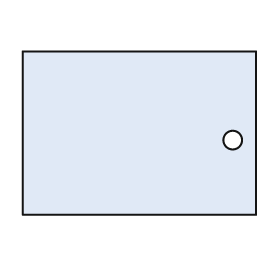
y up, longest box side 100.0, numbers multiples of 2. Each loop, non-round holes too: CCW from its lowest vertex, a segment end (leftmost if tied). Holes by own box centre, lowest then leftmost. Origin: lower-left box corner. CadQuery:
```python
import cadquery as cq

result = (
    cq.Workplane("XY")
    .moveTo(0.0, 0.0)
    .lineTo(100.0, 0.0)
    .lineTo(100.0, 70.0)
    .lineTo(0.0, 70.0)
    .close()
    .moveTo(90.0, 32.0)
    .circle(4.0)
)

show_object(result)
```